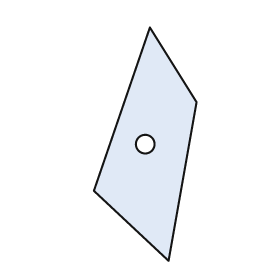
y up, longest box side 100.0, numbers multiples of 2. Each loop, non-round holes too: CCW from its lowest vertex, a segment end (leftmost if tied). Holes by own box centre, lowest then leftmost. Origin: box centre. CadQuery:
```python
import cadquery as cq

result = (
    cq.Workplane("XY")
    .moveTo(10.0, -50.0)
    .lineTo(22.0, 18.0)
    .lineTo(2.0, 50.0)
    .lineTo(-22.0, -20.0)
    .close()
    .moveTo(0.0, 0.0)
    .circle(4.0)
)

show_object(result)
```